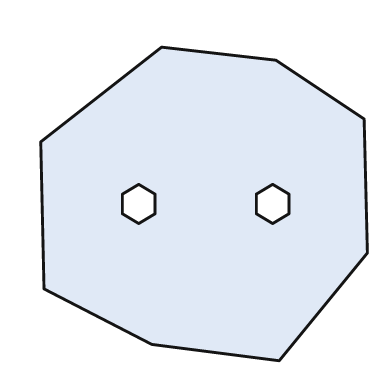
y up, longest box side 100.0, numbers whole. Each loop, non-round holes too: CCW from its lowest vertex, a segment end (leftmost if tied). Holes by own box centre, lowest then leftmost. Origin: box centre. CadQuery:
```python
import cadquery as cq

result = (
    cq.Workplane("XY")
    .moveTo(23.0, -48.0)
    .lineTo(50.0, -15.0)
    .lineTo(49.0, 26.0)
    .lineTo(22.0, 44.0)
    .lineTo(-13.0, 48.0)
    .lineTo(-50.0, 19.0)
    .lineTo(-49.0, -26.0)
    .lineTo(-16.0, -43.0)
    .close()
    .moveTo(-20.0, -6.0)
    .lineTo(-15.0, -3.0)
    .lineTo(-15.0, 3.0)
    .lineTo(-20.0, 6.0)
    .lineTo(-25.0, 3.0)
    .lineTo(-25.0, -3.0)
    .close()
    .moveTo(21.0, -6.0)
    .lineTo(26.0, -3.0)
    .lineTo(26.0, 3.0)
    .lineTo(21.0, 6.0)
    .lineTo(16.0, 3.0)
    .lineTo(16.0, -3.0)
    .close()
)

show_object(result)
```